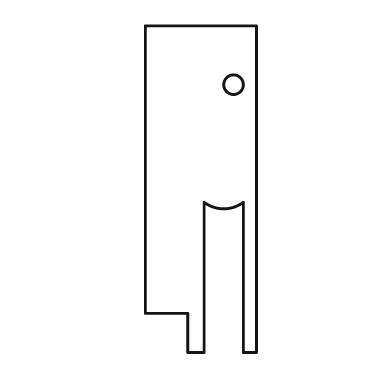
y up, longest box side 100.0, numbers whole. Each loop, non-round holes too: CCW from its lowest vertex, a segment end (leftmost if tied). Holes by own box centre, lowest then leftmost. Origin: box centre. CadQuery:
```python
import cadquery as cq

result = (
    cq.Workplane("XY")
    .moveTo(-4.0, -50.0)
    .lineTo(1.0, -50.0)
    .lineTo(1.0, -4.0)
    .threePointArc((7.0, -6.0), (13.0, -4.0))
    .lineTo(13.0, -50.0)
    .lineTo(17.0, -50.0)
    .lineTo(17.0, 50.0)
    .lineTo(-17.0, 50.0)
    .lineTo(-17.0, -38.0)
    .lineTo(-4.0, -38.0)
    .close()
    .moveTo(10.0, 32.0)
    .circle(3.0)
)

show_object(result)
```